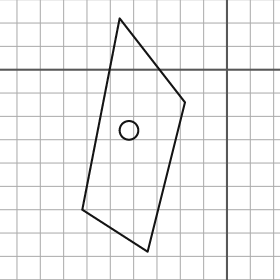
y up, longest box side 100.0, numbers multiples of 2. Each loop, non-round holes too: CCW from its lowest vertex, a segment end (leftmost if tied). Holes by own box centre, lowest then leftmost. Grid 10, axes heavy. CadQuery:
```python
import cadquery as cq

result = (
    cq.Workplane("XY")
    .moveTo(-34.0, -78.0)
    .lineTo(-18.0, -14.0)
    .lineTo(-46.0, 22.0)
    .lineTo(-62.0, -60.0)
    .close()
    .moveTo(-42.0, -26.0)
    .circle(4.0)
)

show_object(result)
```